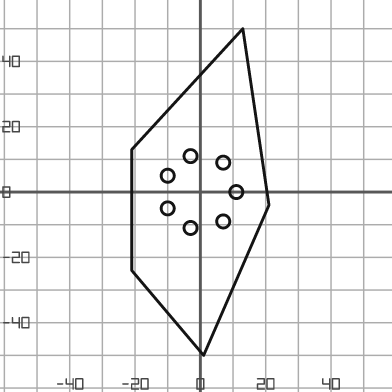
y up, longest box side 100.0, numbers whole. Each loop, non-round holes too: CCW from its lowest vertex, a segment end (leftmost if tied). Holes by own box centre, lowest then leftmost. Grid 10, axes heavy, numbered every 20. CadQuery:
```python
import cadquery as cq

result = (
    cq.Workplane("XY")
    .moveTo(1.0, -50.0)
    .lineTo(21.0, -4.0)
    .lineTo(13.0, 50.0)
    .lineTo(-21.0, 13.0)
    .lineTo(-21.0, -24.0)
    .close()
    .moveTo(-3.0, -11.0)
    .circle(2.0)
    .moveTo(7.0, -9.0)
    .circle(2.0)
    .moveTo(-10.0, -5.0)
    .circle(2.0)
    .moveTo(11.0, 0.0)
    .circle(2.0)
    .moveTo(-10.0, 5.0)
    .circle(2.0)
    .moveTo(7.0, 9.0)
    .circle(2.0)
    .moveTo(-3.0, 11.0)
    .circle(2.0)
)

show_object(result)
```